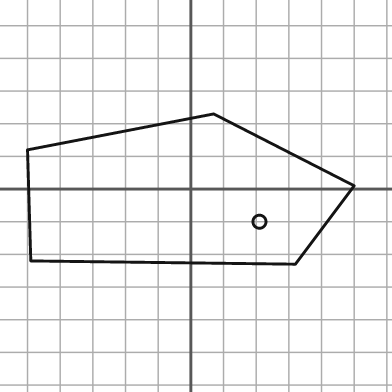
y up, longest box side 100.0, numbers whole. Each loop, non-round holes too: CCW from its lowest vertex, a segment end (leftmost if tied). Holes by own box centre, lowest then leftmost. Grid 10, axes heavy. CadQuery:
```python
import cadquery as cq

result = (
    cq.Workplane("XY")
    .moveTo(32.0, -23.0)
    .lineTo(50.0, 1.0)
    .lineTo(7.0, 23.0)
    .lineTo(-50.0, 12.0)
    .lineTo(-49.0, -22.0)
    .close()
    .moveTo(21.0, -10.0)
    .circle(2.0)
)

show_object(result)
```